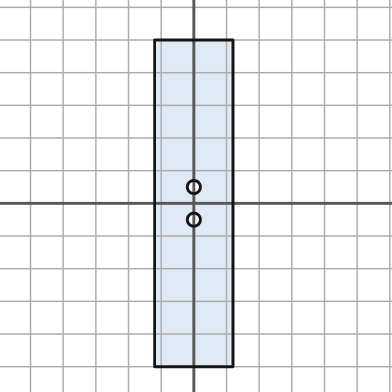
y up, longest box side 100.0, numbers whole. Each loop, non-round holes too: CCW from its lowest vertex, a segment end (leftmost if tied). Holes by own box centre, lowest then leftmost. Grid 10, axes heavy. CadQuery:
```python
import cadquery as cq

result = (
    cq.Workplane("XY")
    .moveTo(-12.0, -50.0)
    .lineTo(12.0, -50.0)
    .lineTo(12.0, 50.0)
    .lineTo(-12.0, 50.0)
    .close()
    .moveTo(0.0, -5.0)
    .circle(2.0)
    .moveTo(0.0, 5.0)
    .circle(2.0)
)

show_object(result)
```